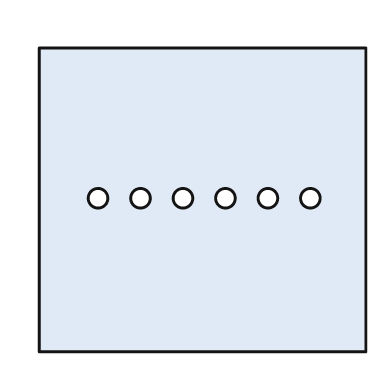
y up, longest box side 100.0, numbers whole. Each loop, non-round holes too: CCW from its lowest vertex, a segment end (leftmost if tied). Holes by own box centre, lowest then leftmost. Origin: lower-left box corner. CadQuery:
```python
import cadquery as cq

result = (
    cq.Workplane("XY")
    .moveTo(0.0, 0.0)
    .lineTo(100.0, 0.0)
    .lineTo(100.0, 93.0)
    .lineTo(0.0, 93.0)
    .close()
    .moveTo(18.0, 47.0)
    .circle(3.0)
    .moveTo(31.0, 47.0)
    .circle(3.0)
    .moveTo(44.0, 47.0)
    .circle(3.0)
    .moveTo(57.0, 47.0)
    .circle(3.0)
    .moveTo(70.0, 47.0)
    .circle(3.0)
    .moveTo(83.0, 47.0)
    .circle(3.0)
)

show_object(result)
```